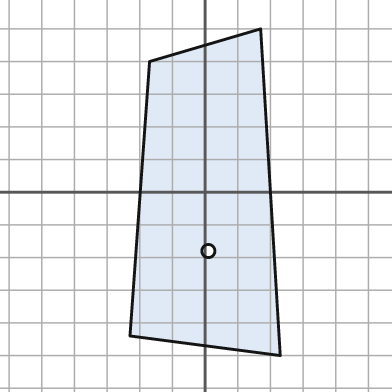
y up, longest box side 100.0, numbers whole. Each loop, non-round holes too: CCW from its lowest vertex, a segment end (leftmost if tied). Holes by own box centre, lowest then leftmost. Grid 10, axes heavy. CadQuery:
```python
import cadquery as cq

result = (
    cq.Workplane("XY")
    .moveTo(23.0, -50.0)
    .lineTo(17.0, 50.0)
    .lineTo(-17.0, 40.0)
    .lineTo(-23.0, -44.0)
    .close()
    .moveTo(1.0, -18.0)
    .circle(2.0)
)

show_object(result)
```